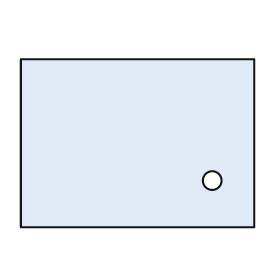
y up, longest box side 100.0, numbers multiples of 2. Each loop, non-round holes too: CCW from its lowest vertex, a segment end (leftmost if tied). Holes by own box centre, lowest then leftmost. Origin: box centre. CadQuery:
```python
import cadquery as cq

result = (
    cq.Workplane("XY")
    .moveTo(-50.0, -36.0)
    .lineTo(50.0, -36.0)
    .lineTo(50.0, 36.0)
    .lineTo(-50.0, 36.0)
    .close()
    .moveTo(32.0, -16.0)
    .circle(4.0)
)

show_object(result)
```